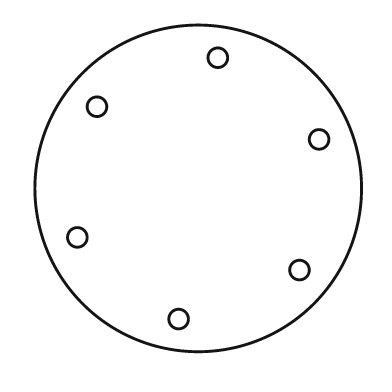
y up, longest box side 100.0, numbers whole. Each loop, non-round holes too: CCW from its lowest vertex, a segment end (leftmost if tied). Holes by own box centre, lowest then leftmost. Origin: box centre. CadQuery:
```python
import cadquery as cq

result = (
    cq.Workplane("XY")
    .moveTo(0.0, 0.0)
    .circle(50.0)
    .moveTo(-6.0, -40.0)
    .circle(3.0)
    .moveTo(31.0, -25.0)
    .circle(3.0)
    .moveTo(-37.0, -15.0)
    .circle(3.0)
    .moveTo(37.0, 15.0)
    .circle(3.0)
    .moveTo(-31.0, 25.0)
    .circle(3.0)
    .moveTo(6.0, 40.0)
    .circle(3.0)
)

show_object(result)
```